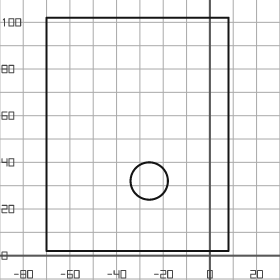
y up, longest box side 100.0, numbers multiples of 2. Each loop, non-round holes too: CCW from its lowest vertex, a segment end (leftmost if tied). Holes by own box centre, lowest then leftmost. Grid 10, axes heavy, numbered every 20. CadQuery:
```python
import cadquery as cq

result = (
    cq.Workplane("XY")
    .moveTo(-70.0, 2.0)
    .lineTo(8.0, 2.0)
    .lineTo(8.0, 102.0)
    .lineTo(-70.0, 102.0)
    .close()
    .moveTo(-26.0, 32.0)
    .circle(8.0)
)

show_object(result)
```